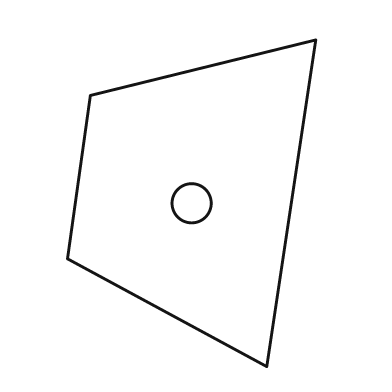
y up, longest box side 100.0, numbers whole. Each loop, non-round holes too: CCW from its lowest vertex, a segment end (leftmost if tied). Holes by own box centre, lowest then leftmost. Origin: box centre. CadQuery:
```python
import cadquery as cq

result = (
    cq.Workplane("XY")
    .moveTo(23.0, -50.0)
    .lineTo(38.0, 50.0)
    .lineTo(-31.0, 33.0)
    .lineTo(-38.0, -17.0)
    .close()
    .moveTo(0.0, 0.0)
    .circle(6.0)
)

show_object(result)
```